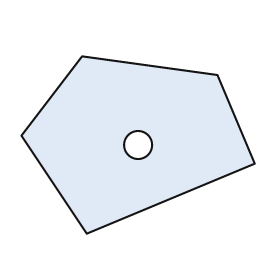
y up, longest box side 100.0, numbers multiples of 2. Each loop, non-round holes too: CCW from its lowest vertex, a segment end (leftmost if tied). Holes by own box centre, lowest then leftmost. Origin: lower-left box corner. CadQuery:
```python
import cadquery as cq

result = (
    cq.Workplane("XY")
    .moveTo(28.0, 0.0)
    .lineTo(100.0, 30.0)
    .lineTo(84.0, 68.0)
    .lineTo(26.0, 76.0)
    .lineTo(0.0, 42.0)
    .close()
    .moveTo(50.0, 38.0)
    .circle(6.0)
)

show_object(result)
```